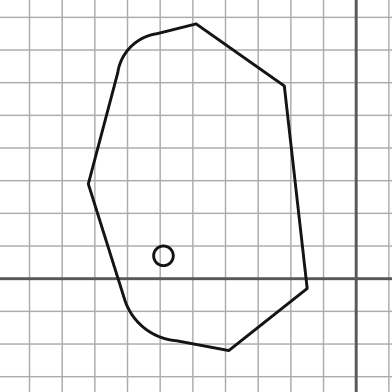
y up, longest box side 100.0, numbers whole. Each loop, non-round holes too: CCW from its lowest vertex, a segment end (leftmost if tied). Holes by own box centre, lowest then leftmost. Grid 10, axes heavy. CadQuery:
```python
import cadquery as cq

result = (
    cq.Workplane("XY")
    .moveTo(-39.0, -22.0)
    .lineTo(-15.0, -3.0)
    .lineTo(-22.0, 59.0)
    .lineTo(-49.0, 78.0)
    .lineTo(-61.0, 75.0)
    .threePointArc((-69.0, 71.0), (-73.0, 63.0))
    .lineTo(-82.0, 29.0)
    .lineTo(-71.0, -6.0)
    .threePointArc((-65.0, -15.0), (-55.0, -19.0))
    .close()
    .moveTo(-59.0, 7.0)
    .circle(3.0)
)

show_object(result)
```